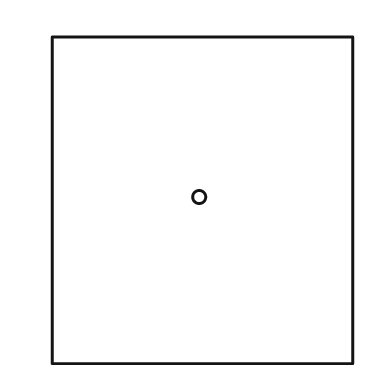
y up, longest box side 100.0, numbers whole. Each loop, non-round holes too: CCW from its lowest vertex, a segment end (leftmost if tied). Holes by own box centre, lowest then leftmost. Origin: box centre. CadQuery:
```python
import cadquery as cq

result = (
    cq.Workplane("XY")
    .moveTo(-46.0, -50.0)
    .lineTo(46.0, -50.0)
    .lineTo(46.0, 50.0)
    .lineTo(-46.0, 50.0)
    .close()
    .moveTo(-1.0, 1.0)
    .circle(2.0)
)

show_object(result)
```